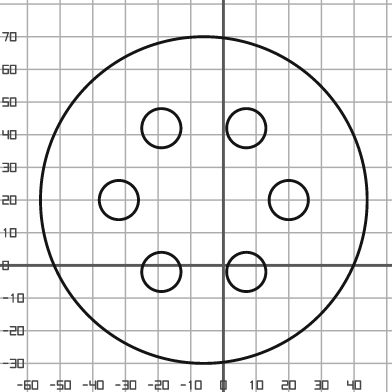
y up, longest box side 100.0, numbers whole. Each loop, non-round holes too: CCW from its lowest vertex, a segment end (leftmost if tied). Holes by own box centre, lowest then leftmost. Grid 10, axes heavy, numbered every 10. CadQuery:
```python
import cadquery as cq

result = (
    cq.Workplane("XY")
    .moveTo(-6.0, 20.0)
    .circle(50.0)
    .moveTo(-19.0, -2.0)
    .circle(6.0)
    .moveTo(7.0, -2.0)
    .circle(6.0)
    .moveTo(-32.0, 20.0)
    .circle(6.0)
    .moveTo(20.0, 20.0)
    .circle(6.0)
    .moveTo(-19.0, 42.0)
    .circle(6.0)
    .moveTo(7.0, 42.0)
    .circle(6.0)
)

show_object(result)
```